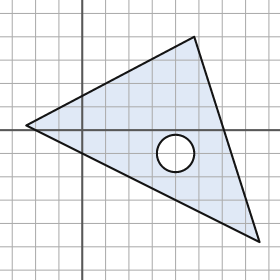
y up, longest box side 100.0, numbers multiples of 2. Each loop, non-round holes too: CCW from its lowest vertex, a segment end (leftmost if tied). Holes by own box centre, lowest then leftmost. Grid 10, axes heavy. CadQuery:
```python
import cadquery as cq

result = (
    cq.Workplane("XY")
    .moveTo(76.0, -48.0)
    .lineTo(48.0, 40.0)
    .lineTo(-24.0, 2.0)
    .close()
    .moveTo(40.0, -10.0)
    .circle(8.0)
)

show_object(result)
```